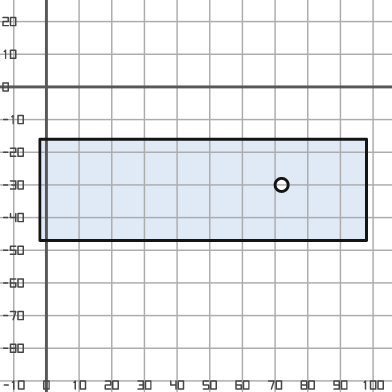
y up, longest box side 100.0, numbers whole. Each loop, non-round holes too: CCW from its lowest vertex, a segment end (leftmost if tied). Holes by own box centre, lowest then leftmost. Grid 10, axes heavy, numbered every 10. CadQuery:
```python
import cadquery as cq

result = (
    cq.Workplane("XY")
    .moveTo(-2.0, -47.0)
    .lineTo(98.0, -47.0)
    .lineTo(98.0, -16.0)
    .lineTo(-2.0, -16.0)
    .close()
    .moveTo(72.0, -30.0)
    .circle(2.0)
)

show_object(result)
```